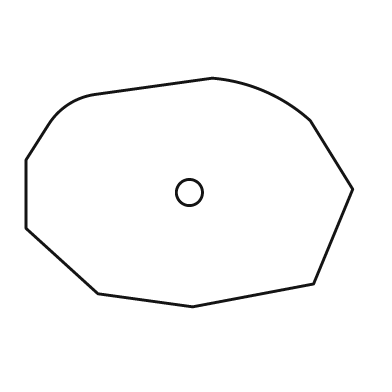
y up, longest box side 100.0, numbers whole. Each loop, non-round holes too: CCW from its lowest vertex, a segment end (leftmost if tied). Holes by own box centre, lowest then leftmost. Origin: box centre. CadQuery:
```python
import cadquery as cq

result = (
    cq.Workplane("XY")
    .moveTo(1.0, -35.0)
    .lineTo(38.0, -28.0)
    .lineTo(50.0, 1.0)
    .lineTo(37.0, 22.0)
    .threePointArc((23.0, 31.0), (7.0, 35.0))
    .lineTo(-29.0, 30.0)
    .threePointArc((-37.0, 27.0), (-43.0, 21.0))
    .lineTo(-50.0, 10.0)
    .lineTo(-50.0, -11.0)
    .lineTo(-28.0, -31.0)
    .close()
    .moveTo(0.0, 0.0)
    .circle(4.0)
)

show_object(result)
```